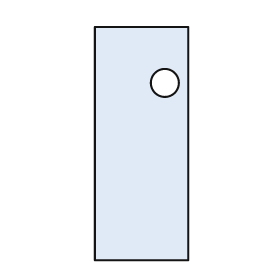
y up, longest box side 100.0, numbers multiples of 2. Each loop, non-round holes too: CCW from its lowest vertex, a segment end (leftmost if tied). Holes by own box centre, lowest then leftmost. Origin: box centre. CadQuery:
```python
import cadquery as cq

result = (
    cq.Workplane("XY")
    .moveTo(-20.0, -50.0)
    .lineTo(20.0, -50.0)
    .lineTo(20.0, 50.0)
    .lineTo(-20.0, 50.0)
    .close()
    .moveTo(10.0, 26.0)
    .circle(6.0)
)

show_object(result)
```